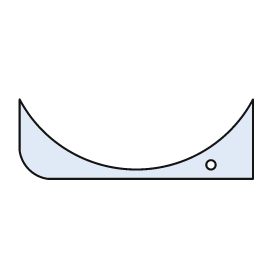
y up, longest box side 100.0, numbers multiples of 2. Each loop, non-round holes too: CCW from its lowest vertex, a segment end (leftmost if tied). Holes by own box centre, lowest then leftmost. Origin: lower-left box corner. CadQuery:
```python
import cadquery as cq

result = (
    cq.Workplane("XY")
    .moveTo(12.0, 0.0)
    .lineTo(100.0, 0.0)
    .lineTo(100.0, 34.0)
    .threePointArc((50.0, 4.0), (0.0, 34.0))
    .lineTo(0.0, 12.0)
    .threePointArc((4.0, 4.0), (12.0, 0.0))
    .close()
    .moveTo(82.0, 6.0)
    .circle(2.0)
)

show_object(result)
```